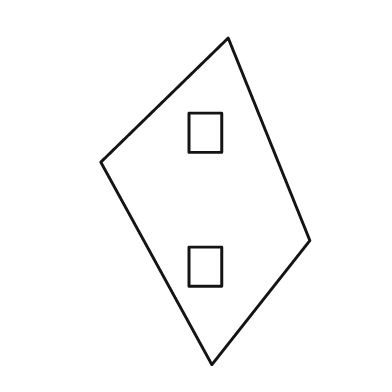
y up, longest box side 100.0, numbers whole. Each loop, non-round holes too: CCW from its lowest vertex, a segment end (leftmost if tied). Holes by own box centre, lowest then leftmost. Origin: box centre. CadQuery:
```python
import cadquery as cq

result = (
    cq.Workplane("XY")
    .moveTo(2.0, -50.0)
    .lineTo(32.0, -12.0)
    .lineTo(7.0, 50.0)
    .lineTo(-32.0, 12.0)
    .close()
    .moveTo(-5.0, -26.0)
    .lineTo(5.0, -26.0)
    .lineTo(5.0, -14.0)
    .lineTo(-5.0, -14.0)
    .close()
    .moveTo(-5.0, 15.0)
    .lineTo(5.0, 15.0)
    .lineTo(5.0, 27.0)
    .lineTo(-5.0, 27.0)
    .close()
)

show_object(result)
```